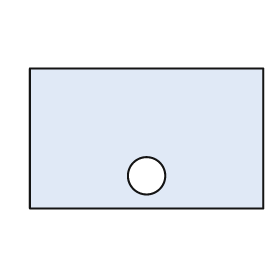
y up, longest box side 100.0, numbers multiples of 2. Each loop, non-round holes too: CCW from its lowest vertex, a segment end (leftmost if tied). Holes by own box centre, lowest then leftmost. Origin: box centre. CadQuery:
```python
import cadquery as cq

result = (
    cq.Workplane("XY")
    .moveTo(-50.0, -30.0)
    .lineTo(50.0, -30.0)
    .lineTo(50.0, 30.0)
    .lineTo(-50.0, 30.0)
    .close()
    .moveTo(0.0, -16.0)
    .circle(8.0)
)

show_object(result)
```